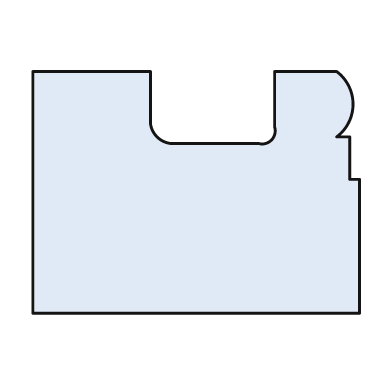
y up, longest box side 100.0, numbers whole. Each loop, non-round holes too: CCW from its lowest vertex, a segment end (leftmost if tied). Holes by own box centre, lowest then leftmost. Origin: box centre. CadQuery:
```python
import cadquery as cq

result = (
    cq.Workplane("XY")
    .moveTo(-50.0, -37.0)
    .lineTo(50.0, -37.0)
    .lineTo(50.0, 4.0)
    .lineTo(47.0, 4.0)
    .lineTo(47.0, 17.0)
    .lineTo(43.0, 17.0)
    .threePointArc((48.0, 27.0), (43.0, 37.0))
    .lineTo(24.0, 37.0)
    .lineTo(24.0, 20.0)
    .threePointArc((23.0, 16.0), (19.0, 15.0))
    .lineTo(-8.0, 15.0)
    .threePointArc((-12.0, 17.0), (-14.0, 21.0))
    .lineTo(-14.0, 37.0)
    .lineTo(-50.0, 37.0)
    .close()
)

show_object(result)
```